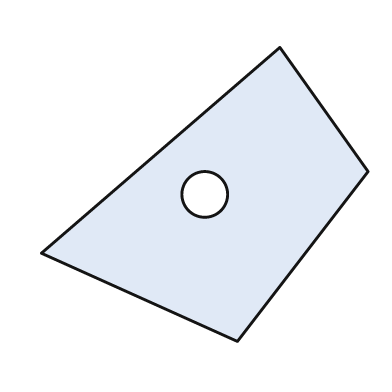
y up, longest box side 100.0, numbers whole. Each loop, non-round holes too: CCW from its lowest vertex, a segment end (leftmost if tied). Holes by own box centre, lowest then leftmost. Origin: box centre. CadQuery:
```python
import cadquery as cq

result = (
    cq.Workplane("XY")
    .moveTo(10.0, -45.0)
    .lineTo(50.0, 7.0)
    .lineTo(23.0, 45.0)
    .lineTo(-50.0, -18.0)
    .close()
    .moveTo(0.0, 0.0)
    .circle(7.0)
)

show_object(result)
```